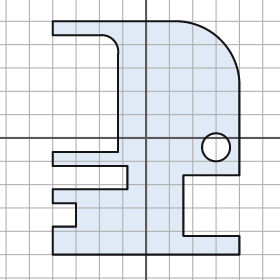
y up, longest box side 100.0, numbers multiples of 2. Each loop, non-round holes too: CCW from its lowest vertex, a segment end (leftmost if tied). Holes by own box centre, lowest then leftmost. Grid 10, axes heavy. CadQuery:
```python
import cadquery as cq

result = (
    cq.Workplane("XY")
    .moveTo(-40.0, -50.0)
    .lineTo(40.0, -50.0)
    .lineTo(40.0, -42.0)
    .lineTo(16.0, -42.0)
    .lineTo(16.0, -16.0)
    .lineTo(40.0, -16.0)
    .lineTo(40.0, 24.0)
    .threePointArc((32.0, 42.0), (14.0, 50.0))
    .lineTo(-40.0, 50.0)
    .lineTo(-40.0, 44.0)
    .lineTo(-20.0, 44.0)
    .threePointArc((-14.0, 42.0), (-12.0, 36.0))
    .lineTo(-12.0, -6.0)
    .lineTo(-40.0, -6.0)
    .lineTo(-40.0, -12.0)
    .lineTo(-8.0, -12.0)
    .lineTo(-8.0, -22.0)
    .lineTo(-40.0, -22.0)
    .lineTo(-40.0, -28.0)
    .lineTo(-30.0, -28.0)
    .lineTo(-30.0, -38.0)
    .lineTo(-40.0, -38.0)
    .close()
    .moveTo(30.0, -4.0)
    .circle(6.0)
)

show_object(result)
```